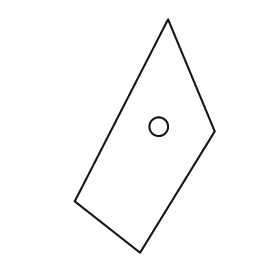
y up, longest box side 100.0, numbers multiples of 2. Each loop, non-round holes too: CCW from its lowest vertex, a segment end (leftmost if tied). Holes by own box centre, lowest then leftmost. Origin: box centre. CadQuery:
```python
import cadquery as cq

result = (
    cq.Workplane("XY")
    .moveTo(-2.0, -50.0)
    .lineTo(30.0, 2.0)
    .lineTo(10.0, 50.0)
    .lineTo(-30.0, -28.0)
    .close()
    .moveTo(6.0, 4.0)
    .circle(4.0)
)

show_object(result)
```